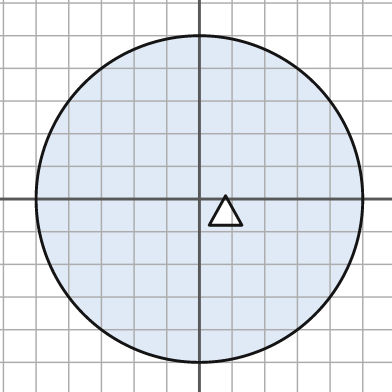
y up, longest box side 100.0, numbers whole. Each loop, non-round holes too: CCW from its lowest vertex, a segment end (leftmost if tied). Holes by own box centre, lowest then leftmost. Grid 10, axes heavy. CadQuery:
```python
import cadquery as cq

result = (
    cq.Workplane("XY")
    .moveTo(0.0, 0.0)
    .circle(50.0)
    .moveTo(3.0, -8.0)
    .lineTo(13.0, -8.0)
    .lineTo(8.0, 1.0)
    .close()
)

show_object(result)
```